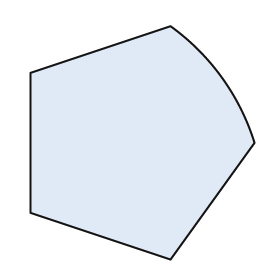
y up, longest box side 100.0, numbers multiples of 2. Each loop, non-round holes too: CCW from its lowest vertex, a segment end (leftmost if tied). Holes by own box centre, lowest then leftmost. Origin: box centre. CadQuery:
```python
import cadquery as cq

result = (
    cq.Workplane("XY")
    .moveTo(12.0, -50.0)
    .lineTo(48.0, 0.0)
    .threePointArc((34.0, 28.0), (12.0, 50.0))
    .lineTo(-48.0, 30.0)
    .lineTo(-48.0, -30.0)
    .close()
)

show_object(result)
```